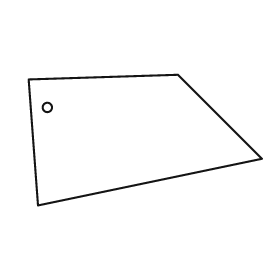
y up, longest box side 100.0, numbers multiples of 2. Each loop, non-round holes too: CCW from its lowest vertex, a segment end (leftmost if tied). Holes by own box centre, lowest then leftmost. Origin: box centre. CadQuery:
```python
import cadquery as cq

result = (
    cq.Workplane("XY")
    .moveTo(-46.0, -28.0)
    .lineTo(50.0, -8.0)
    .lineTo(14.0, 28.0)
    .lineTo(-50.0, 26.0)
    .close()
    .moveTo(-42.0, 14.0)
    .circle(2.0)
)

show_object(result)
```